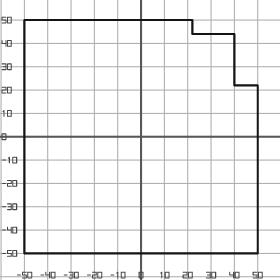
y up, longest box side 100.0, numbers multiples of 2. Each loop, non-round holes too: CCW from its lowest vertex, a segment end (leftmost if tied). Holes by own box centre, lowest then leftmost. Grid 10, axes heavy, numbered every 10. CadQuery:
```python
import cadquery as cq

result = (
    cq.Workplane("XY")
    .moveTo(-50.0, -50.0)
    .lineTo(50.0, -50.0)
    .lineTo(50.0, 22.0)
    .lineTo(40.0, 22.0)
    .lineTo(40.0, 44.0)
    .lineTo(22.0, 44.0)
    .lineTo(22.0, 50.0)
    .lineTo(-50.0, 50.0)
    .close()
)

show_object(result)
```